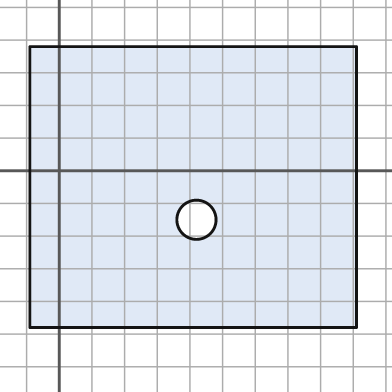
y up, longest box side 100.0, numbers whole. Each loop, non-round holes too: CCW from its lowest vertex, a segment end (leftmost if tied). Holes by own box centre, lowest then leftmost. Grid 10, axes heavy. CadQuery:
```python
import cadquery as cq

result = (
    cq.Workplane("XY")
    .moveTo(-9.0, -48.0)
    .lineTo(91.0, -48.0)
    .lineTo(91.0, 38.0)
    .lineTo(-9.0, 38.0)
    .close()
    .moveTo(42.0, -15.0)
    .circle(6.0)
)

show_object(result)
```